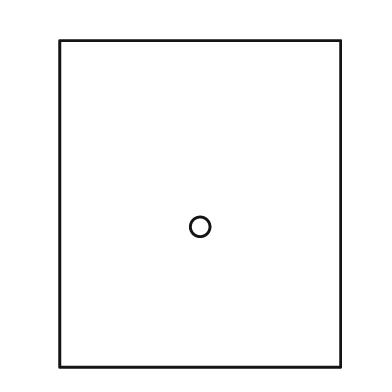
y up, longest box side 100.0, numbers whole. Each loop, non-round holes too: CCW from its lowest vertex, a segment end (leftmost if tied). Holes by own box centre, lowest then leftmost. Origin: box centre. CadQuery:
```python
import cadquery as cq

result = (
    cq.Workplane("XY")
    .moveTo(-43.0, -50.0)
    .lineTo(43.0, -50.0)
    .lineTo(43.0, 50.0)
    .lineTo(-43.0, 50.0)
    .close()
    .moveTo(0.0, -7.0)
    .circle(3.0)
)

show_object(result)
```